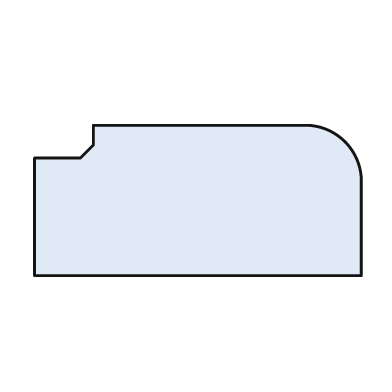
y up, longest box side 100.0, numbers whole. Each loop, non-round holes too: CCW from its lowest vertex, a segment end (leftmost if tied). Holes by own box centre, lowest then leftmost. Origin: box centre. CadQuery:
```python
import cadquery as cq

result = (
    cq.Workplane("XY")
    .moveTo(-50.0, -23.0)
    .lineTo(50.0, -23.0)
    .lineTo(50.0, 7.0)
    .threePointArc((45.0, 18.0), (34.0, 23.0))
    .lineTo(-32.0, 23.0)
    .lineTo(-32.0, 17.0)
    .lineTo(-36.0, 13.0)
    .lineTo(-50.0, 13.0)
    .close()
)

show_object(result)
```